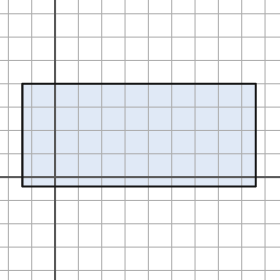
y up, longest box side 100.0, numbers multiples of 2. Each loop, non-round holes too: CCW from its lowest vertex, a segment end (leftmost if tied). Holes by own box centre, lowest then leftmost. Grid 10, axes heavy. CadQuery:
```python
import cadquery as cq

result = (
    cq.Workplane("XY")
    .moveTo(-14.0, -4.0)
    .lineTo(86.0, -4.0)
    .lineTo(86.0, 40.0)
    .lineTo(-14.0, 40.0)
    .close()
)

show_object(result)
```